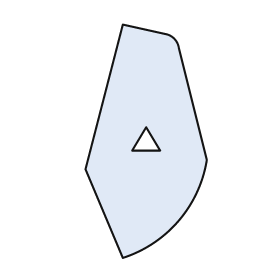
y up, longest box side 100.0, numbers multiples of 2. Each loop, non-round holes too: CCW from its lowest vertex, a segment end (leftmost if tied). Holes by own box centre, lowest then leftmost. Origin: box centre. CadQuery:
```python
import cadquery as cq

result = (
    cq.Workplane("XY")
    .moveTo(-10.0, -50.0)
    .threePointArc((14.0, -34.0), (26.0, -8.0))
    .lineTo(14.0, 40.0)
    .threePointArc((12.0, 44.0), (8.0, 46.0))
    .lineTo(-10.0, 50.0)
    .lineTo(-26.0, -12.0)
    .close()
    .moveTo(-6.0, -4.0)
    .lineTo(6.0, -4.0)
    .lineTo(0.0, 6.0)
    .close()
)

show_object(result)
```